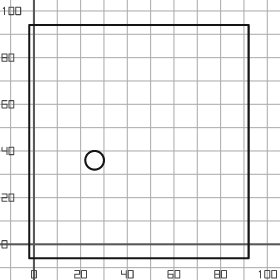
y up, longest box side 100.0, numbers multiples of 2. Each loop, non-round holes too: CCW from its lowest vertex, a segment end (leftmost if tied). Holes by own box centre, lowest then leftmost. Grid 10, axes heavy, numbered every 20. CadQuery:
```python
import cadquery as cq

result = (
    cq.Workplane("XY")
    .moveTo(-2.0, -6.0)
    .lineTo(92.0, -6.0)
    .lineTo(92.0, 94.0)
    .lineTo(-2.0, 94.0)
    .close()
    .moveTo(26.0, 36.0)
    .circle(4.0)
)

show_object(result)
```